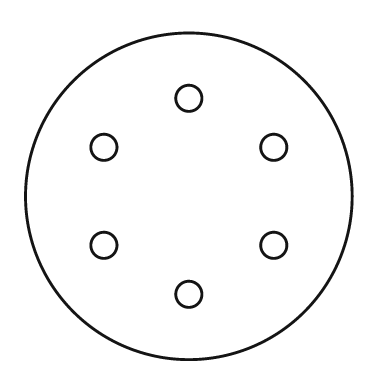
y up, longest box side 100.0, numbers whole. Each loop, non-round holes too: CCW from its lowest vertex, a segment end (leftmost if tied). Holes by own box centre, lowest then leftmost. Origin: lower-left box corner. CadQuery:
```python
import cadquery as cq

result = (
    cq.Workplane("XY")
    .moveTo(50.0, 50.0)
    .circle(50.0)
    .moveTo(50.0, 20.0)
    .circle(4.0)
    .moveTo(24.0, 35.0)
    .circle(4.0)
    .moveTo(76.0, 35.0)
    .circle(4.0)
    .moveTo(24.0, 65.0)
    .circle(4.0)
    .moveTo(76.0, 65.0)
    .circle(4.0)
    .moveTo(50.0, 80.0)
    .circle(4.0)
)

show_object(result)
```